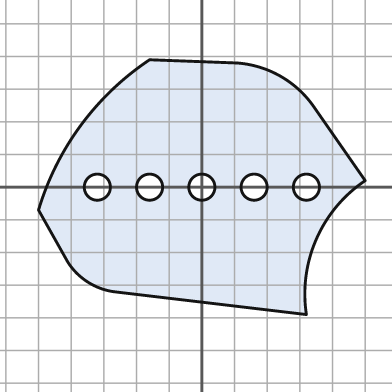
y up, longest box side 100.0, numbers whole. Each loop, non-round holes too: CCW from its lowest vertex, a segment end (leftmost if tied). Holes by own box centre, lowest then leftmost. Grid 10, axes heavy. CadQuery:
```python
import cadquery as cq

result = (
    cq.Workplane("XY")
    .moveTo(32.0, -39.0)
    .threePointArc((35.0, -16.0), (50.0, 2.0))
    .lineTo(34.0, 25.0)
    .threePointArc((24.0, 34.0), (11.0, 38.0))
    .lineTo(-16.0, 39.0)
    .threePointArc((-37.0, 19.0), (-50.0, -7.0))
    .lineTo(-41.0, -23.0)
    .threePointArc((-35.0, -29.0), (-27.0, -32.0))
    .close()
    .moveTo(-32.0, 0.0)
    .circle(4.0)
    .moveTo(-16.0, 0.0)
    .circle(4.0)
    .moveTo(0.0, 0.0)
    .circle(4.0)
    .moveTo(16.0, 0.0)
    .circle(4.0)
    .moveTo(32.0, 0.0)
    .circle(4.0)
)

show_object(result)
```